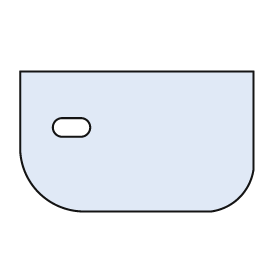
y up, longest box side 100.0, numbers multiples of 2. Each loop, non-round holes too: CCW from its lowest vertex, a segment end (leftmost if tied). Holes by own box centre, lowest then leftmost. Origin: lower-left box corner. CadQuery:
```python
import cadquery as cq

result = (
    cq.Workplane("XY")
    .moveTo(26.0, 0.0)
    .lineTo(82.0, 0.0)
    .threePointArc((94.0, 6.0), (100.0, 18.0))
    .lineTo(100.0, 60.0)
    .lineTo(0.0, 60.0)
    .lineTo(0.0, 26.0)
    .threePointArc((8.0, 8.0), (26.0, 0.0))
    .close()
    .moveTo(18.0, 32.0)
    .lineTo(26.0, 32.0)
    .threePointArc((30.0, 36.0), (26.0, 40.0))
    .lineTo(18.0, 40.0)
    .threePointArc((14.0, 36.0), (18.0, 32.0))
    .close()
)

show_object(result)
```